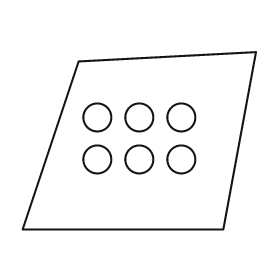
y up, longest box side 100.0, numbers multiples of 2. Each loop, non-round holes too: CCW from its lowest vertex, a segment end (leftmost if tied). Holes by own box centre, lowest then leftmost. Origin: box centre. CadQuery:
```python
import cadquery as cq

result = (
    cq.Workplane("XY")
    .moveTo(-50.0, -38.0)
    .lineTo(36.0, -38.0)
    .lineTo(50.0, 38.0)
    .lineTo(-26.0, 34.0)
    .close()
    .moveTo(-18.0, -8.0)
    .circle(6.0)
    .moveTo(0.0, -8.0)
    .circle(6.0)
    .moveTo(18.0, -8.0)
    .circle(6.0)
    .moveTo(-18.0, 10.0)
    .circle(6.0)
    .moveTo(0.0, 10.0)
    .circle(6.0)
    .moveTo(18.0, 10.0)
    .circle(6.0)
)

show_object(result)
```